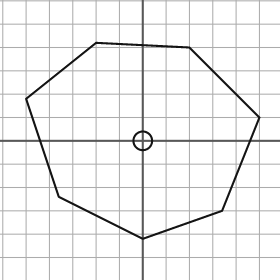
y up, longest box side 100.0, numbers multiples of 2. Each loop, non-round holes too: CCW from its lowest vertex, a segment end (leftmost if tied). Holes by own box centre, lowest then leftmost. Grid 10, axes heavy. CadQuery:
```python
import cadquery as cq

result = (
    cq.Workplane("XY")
    .moveTo(0.0, -42.0)
    .lineTo(34.0, -30.0)
    .lineTo(50.0, 10.0)
    .lineTo(20.0, 40.0)
    .lineTo(-20.0, 42.0)
    .lineTo(-50.0, 18.0)
    .lineTo(-36.0, -24.0)
    .close()
    .moveTo(0.0, 0.0)
    .circle(4.0)
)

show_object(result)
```